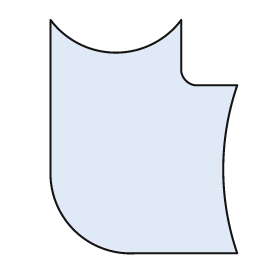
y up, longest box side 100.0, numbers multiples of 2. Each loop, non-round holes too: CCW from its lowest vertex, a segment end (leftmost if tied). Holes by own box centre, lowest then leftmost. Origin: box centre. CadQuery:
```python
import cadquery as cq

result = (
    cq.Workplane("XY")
    .moveTo(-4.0, -50.0)
    .lineTo(40.0, -50.0)
    .threePointArc((34.0, -14.0), (40.0, 22.0))
    .lineTo(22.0, 22.0)
    .threePointArc((18.0, 24.0), (16.0, 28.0))
    .lineTo(16.0, 50.0)
    .threePointArc((-12.0, 36.0), (-40.0, 50.0))
    .lineTo(-40.0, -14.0)
    .threePointArc((-30.0, -40.0), (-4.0, -50.0))
    .close()
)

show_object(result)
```